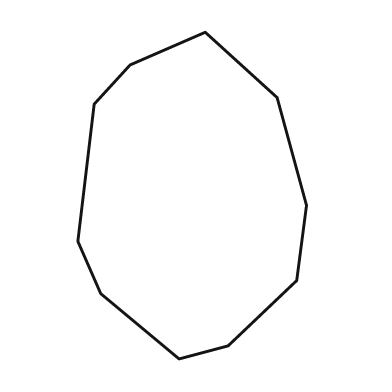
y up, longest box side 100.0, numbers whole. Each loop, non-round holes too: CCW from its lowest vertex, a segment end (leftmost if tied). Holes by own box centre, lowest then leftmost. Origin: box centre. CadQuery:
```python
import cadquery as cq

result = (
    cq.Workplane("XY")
    .moveTo(-4.0, -50.0)
    .lineTo(11.0, -46.0)
    .lineTo(32.0, -26.0)
    .lineTo(35.0, -3.0)
    .lineTo(26.0, 30.0)
    .lineTo(4.0, 50.0)
    .lineTo(-19.0, 40.0)
    .lineTo(-30.0, 28.0)
    .lineTo(-35.0, -14.0)
    .lineTo(-28.0, -30.0)
    .close()
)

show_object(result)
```